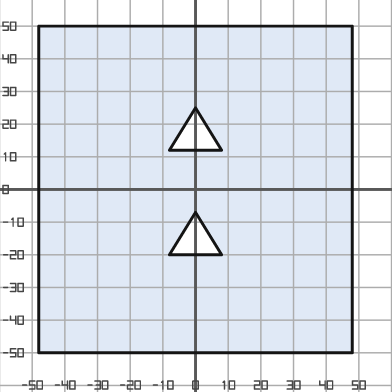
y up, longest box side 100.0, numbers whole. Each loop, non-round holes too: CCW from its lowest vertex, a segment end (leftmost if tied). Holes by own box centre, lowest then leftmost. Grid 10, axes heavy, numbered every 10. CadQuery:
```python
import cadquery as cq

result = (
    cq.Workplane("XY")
    .moveTo(-48.0, -50.0)
    .lineTo(48.0, -50.0)
    .lineTo(48.0, 50.0)
    .lineTo(-48.0, 50.0)
    .close()
    .moveTo(-8.0, -20.0)
    .lineTo(8.0, -20.0)
    .lineTo(0.0, -7.0)
    .close()
    .moveTo(-8.0, 12.0)
    .lineTo(8.0, 12.0)
    .lineTo(0.0, 25.0)
    .close()
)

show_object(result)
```